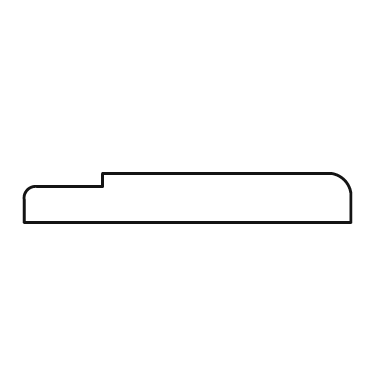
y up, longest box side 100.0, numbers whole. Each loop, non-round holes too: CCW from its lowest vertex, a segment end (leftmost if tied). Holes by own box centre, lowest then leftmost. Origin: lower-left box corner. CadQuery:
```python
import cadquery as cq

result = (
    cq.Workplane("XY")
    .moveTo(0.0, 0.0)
    .lineTo(100.0, 0.0)
    .lineTo(100.0, 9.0)
    .threePointArc((98.0, 13.0), (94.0, 15.0))
    .lineTo(24.0, 15.0)
    .lineTo(24.0, 11.0)
    .lineTo(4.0, 11.0)
    .threePointArc((1.0, 10.0), (0.0, 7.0))
    .close()
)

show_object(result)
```